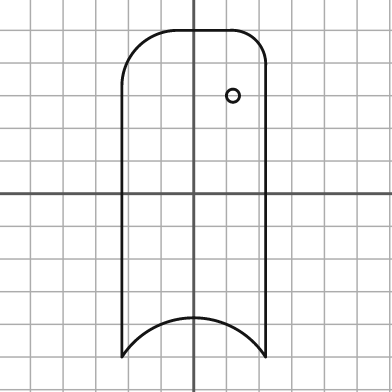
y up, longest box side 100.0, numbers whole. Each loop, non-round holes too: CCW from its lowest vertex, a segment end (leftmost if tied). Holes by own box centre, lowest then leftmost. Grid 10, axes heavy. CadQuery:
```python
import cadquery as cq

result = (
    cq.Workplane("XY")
    .moveTo(-22.0, -50.0)
    .threePointArc((0.0, -38.0), (22.0, -50.0))
    .lineTo(22.0, 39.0)
    .threePointArc((19.0, 47.0), (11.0, 50.0))
    .lineTo(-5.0, 50.0)
    .threePointArc((-17.0, 45.0), (-22.0, 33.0))
    .close()
    .moveTo(12.0, 30.0)
    .circle(2.0)
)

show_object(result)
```